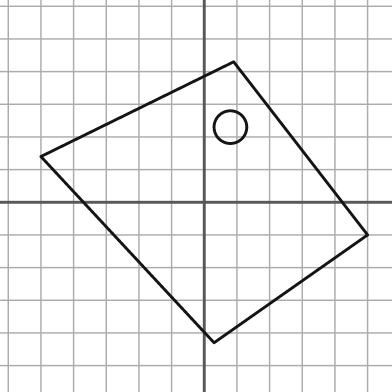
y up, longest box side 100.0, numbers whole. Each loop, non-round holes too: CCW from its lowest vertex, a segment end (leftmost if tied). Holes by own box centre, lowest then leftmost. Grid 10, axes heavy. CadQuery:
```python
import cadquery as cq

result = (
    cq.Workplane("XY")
    .moveTo(3.0, -43.0)
    .lineTo(50.0, -10.0)
    .lineTo(9.0, 43.0)
    .lineTo(-50.0, 14.0)
    .close()
    .moveTo(8.0, 23.0)
    .circle(5.0)
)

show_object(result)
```